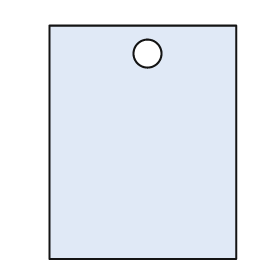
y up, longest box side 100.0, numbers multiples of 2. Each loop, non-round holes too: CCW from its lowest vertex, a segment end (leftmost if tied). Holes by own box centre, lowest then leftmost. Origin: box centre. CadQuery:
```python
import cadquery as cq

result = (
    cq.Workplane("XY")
    .moveTo(-40.0, -50.0)
    .lineTo(40.0, -50.0)
    .lineTo(40.0, 50.0)
    .lineTo(-40.0, 50.0)
    .close()
    .moveTo(2.0, 38.0)
    .circle(6.0)
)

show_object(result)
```